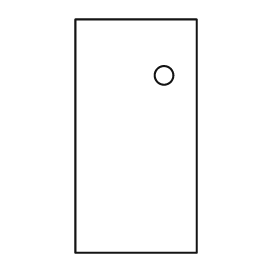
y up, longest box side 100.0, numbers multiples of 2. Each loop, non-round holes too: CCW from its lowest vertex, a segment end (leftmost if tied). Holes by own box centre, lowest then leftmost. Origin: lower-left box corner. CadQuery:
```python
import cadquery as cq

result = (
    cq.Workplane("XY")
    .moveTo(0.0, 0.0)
    .lineTo(52.0, 0.0)
    .lineTo(52.0, 100.0)
    .lineTo(0.0, 100.0)
    .close()
    .moveTo(38.0, 76.0)
    .circle(4.0)
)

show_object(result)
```